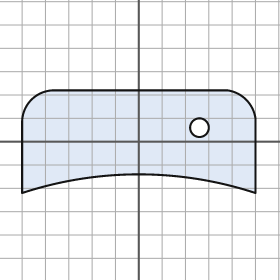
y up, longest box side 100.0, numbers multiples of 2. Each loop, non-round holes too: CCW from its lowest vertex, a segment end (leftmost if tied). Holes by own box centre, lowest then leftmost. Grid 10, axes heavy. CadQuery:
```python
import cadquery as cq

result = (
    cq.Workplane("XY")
    .moveTo(-50.0, -22.0)
    .threePointArc((0.0, -14.0), (50.0, -22.0))
    .lineTo(50.0, 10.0)
    .threePointArc((46.0, 18.0), (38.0, 22.0))
    .lineTo(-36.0, 22.0)
    .threePointArc((-46.0, 18.0), (-50.0, 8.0))
    .close()
    .moveTo(26.0, 6.0)
    .circle(4.0)
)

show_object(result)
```